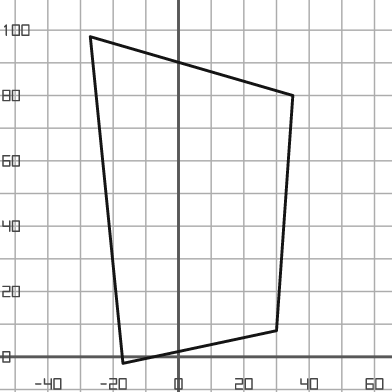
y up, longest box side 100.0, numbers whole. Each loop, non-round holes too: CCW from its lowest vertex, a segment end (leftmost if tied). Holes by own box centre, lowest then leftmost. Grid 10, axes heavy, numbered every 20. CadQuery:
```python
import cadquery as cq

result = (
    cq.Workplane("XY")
    .moveTo(-17.0, -2.0)
    .lineTo(30.0, 8.0)
    .lineTo(35.0, 80.0)
    .lineTo(-27.0, 98.0)
    .close()
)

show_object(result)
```